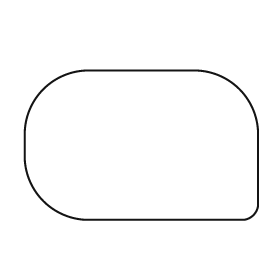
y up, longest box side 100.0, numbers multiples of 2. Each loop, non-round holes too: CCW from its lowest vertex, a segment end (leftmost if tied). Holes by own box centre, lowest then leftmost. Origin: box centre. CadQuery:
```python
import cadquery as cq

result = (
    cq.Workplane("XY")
    .moveTo(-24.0, -32.0)
    .lineTo(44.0, -32.0)
    .threePointArc((48.0, -30.0), (50.0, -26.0))
    .lineTo(50.0, 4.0)
    .threePointArc((42.0, 24.0), (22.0, 32.0))
    .lineTo(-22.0, 32.0)
    .threePointArc((-42.0, 24.0), (-50.0, 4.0))
    .lineTo(-50.0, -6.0)
    .threePointArc((-42.0, -24.0), (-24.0, -32.0))
    .close()
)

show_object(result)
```